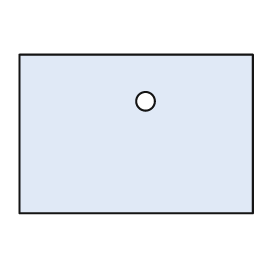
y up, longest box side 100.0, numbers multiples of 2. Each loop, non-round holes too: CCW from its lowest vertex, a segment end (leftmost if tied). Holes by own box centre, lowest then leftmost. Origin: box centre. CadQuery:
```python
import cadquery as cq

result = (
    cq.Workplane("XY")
    .moveTo(-50.0, -34.0)
    .lineTo(50.0, -34.0)
    .lineTo(50.0, 34.0)
    .lineTo(-50.0, 34.0)
    .close()
    .moveTo(4.0, 14.0)
    .circle(4.0)
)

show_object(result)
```